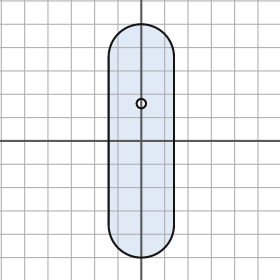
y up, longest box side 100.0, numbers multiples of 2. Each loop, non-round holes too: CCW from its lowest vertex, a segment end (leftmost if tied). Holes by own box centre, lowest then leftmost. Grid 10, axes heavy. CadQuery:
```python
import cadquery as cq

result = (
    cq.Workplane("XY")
    .moveTo(-14.0, -36.0)
    .threePointArc((0.0, -50.0), (14.0, -36.0))
    .lineTo(14.0, 36.0)
    .threePointArc((0.0, 50.0), (-14.0, 36.0))
    .close()
    .moveTo(0.0, 16.0)
    .circle(2.0)
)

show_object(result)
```